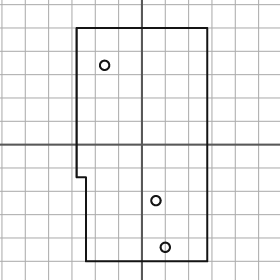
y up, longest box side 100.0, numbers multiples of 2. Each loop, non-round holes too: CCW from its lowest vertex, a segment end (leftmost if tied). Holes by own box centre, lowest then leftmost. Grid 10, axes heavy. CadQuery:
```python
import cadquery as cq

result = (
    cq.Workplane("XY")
    .moveTo(-24.0, -50.0)
    .lineTo(28.0, -50.0)
    .lineTo(28.0, 50.0)
    .lineTo(-28.0, 50.0)
    .lineTo(-28.0, -14.0)
    .lineTo(-24.0, -14.0)
    .close()
    .moveTo(10.0, -44.0)
    .circle(2.0)
    .moveTo(6.0, -24.0)
    .circle(2.0)
    .moveTo(-16.0, 34.0)
    .circle(2.0)
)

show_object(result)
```